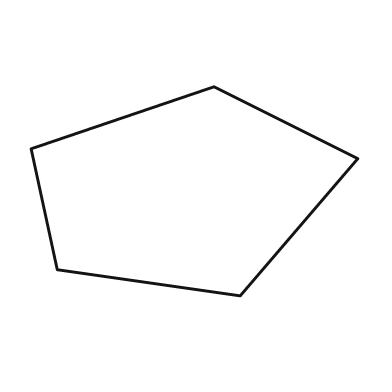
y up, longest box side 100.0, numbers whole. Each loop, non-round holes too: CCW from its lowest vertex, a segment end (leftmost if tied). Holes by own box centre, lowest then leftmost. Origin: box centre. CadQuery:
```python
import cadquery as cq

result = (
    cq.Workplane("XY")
    .moveTo(14.0, -32.0)
    .lineTo(50.0, 10.0)
    .lineTo(6.0, 32.0)
    .lineTo(-50.0, 13.0)
    .lineTo(-42.0, -24.0)
    .close()
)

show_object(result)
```